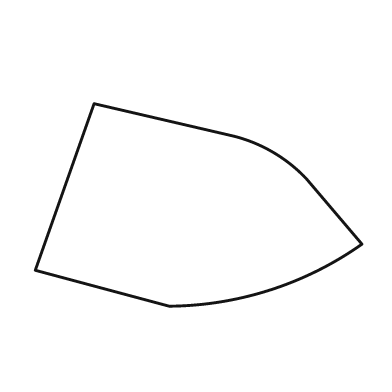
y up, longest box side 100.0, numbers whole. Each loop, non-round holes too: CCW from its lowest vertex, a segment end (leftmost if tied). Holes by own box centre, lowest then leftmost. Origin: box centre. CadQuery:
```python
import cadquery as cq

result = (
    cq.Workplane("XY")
    .moveTo(-9.0, -31.0)
    .threePointArc((22.0, -26.0), (50.0, -12.0))
    .lineTo(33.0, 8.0)
    .threePointArc((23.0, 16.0), (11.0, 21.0))
    .lineTo(-32.0, 31.0)
    .lineTo(-50.0, -20.0)
    .close()
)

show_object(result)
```